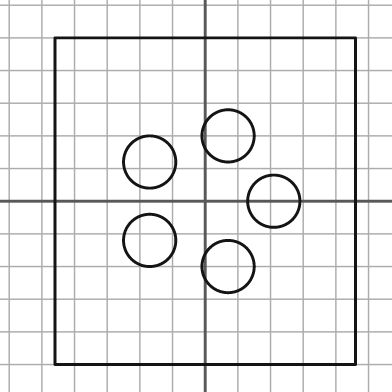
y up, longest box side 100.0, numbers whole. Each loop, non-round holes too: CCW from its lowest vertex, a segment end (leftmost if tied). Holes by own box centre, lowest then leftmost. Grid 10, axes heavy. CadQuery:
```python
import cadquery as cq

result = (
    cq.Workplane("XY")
    .moveTo(-46.0, -50.0)
    .lineTo(46.0, -50.0)
    .lineTo(46.0, 50.0)
    .lineTo(-46.0, 50.0)
    .close()
    .moveTo(7.0, -20.0)
    .circle(8.0)
    .moveTo(-17.0, -12.0)
    .circle(8.0)
    .moveTo(21.0, 0.0)
    .circle(8.0)
    .moveTo(-17.0, 12.0)
    .circle(8.0)
    .moveTo(7.0, 20.0)
    .circle(8.0)
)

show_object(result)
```